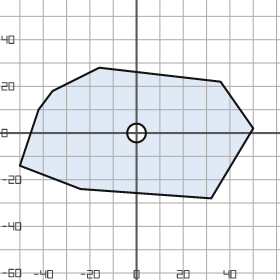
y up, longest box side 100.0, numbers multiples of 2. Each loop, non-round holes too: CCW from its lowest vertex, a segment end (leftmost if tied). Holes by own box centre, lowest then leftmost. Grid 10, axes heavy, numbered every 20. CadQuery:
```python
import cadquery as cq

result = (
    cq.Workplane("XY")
    .moveTo(32.0, -28.0)
    .lineTo(50.0, 2.0)
    .lineTo(36.0, 22.0)
    .lineTo(-16.0, 28.0)
    .lineTo(-36.0, 18.0)
    .lineTo(-42.0, 10.0)
    .lineTo(-50.0, -14.0)
    .lineTo(-24.0, -24.0)
    .close()
    .moveTo(0.0, 0.0)
    .circle(4.0)
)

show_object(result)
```